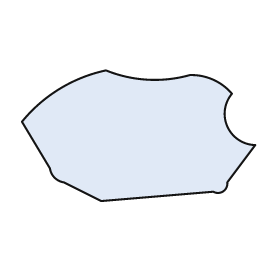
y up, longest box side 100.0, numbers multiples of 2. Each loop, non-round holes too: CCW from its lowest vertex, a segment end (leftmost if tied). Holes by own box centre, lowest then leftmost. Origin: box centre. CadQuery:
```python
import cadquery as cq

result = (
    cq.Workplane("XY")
    .moveTo(-16.0, -28.0)
    .lineTo(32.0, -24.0)
    .threePointArc((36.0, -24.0), (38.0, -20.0))
    .lineTo(50.0, -4.0)
    .threePointArc((38.0, 4.0), (40.0, 18.0))
    .threePointArc((32.0, 24.0), (22.0, 26.0))
    .threePointArc((4.0, 24.0), (-14.0, 28.0))
    .threePointArc((-34.0, 20.0), (-50.0, 6.0))
    .lineTo(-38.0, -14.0)
    .threePointArc((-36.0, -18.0), (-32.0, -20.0))
    .close()
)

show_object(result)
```